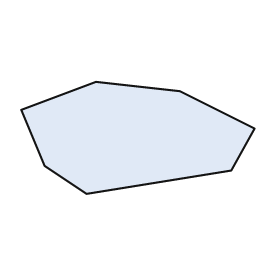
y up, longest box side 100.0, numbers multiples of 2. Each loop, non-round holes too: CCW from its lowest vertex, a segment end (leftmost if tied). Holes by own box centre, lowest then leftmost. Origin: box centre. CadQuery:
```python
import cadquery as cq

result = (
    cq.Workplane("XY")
    .moveTo(-22.0, -24.0)
    .lineTo(40.0, -14.0)
    .lineTo(50.0, 4.0)
    .lineTo(18.0, 20.0)
    .lineTo(-18.0, 24.0)
    .lineTo(-50.0, 12.0)
    .lineTo(-40.0, -12.0)
    .close()
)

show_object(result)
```